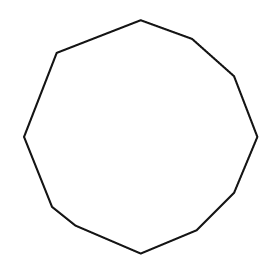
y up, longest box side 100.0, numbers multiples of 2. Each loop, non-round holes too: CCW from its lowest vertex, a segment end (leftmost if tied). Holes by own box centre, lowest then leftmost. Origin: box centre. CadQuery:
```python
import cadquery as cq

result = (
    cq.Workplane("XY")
    .moveTo(0.0, -50.0)
    .lineTo(24.0, -40.0)
    .lineTo(40.0, -24.0)
    .lineTo(50.0, 0.0)
    .lineTo(40.0, 26.0)
    .lineTo(22.0, 42.0)
    .lineTo(0.0, 50.0)
    .lineTo(-36.0, 36.0)
    .lineTo(-50.0, 0.0)
    .lineTo(-38.0, -30.0)
    .lineTo(-28.0, -38.0)
    .close()
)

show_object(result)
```